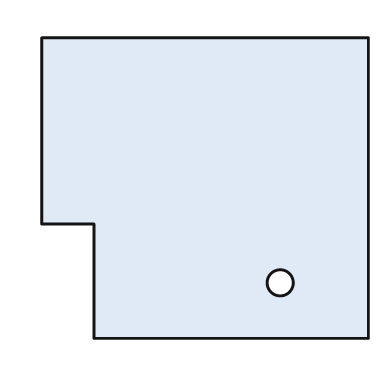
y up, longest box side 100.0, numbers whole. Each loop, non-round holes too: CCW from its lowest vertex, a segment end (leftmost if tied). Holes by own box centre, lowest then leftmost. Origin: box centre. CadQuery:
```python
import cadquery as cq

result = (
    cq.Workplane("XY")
    .moveTo(-34.0, -46.0)
    .lineTo(50.0, -46.0)
    .lineTo(50.0, 46.0)
    .lineTo(-50.0, 46.0)
    .lineTo(-50.0, -11.0)
    .lineTo(-34.0, -11.0)
    .close()
    .moveTo(23.0, -29.0)
    .circle(4.0)
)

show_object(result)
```